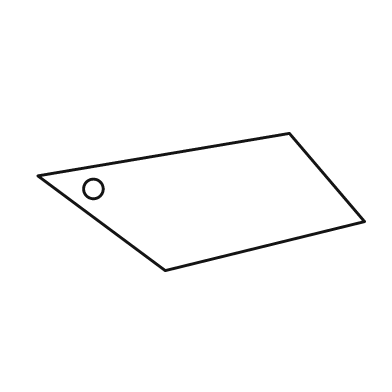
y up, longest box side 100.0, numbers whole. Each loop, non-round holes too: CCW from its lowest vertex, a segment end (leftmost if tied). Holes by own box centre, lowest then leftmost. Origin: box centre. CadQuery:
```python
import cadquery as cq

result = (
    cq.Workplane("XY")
    .moveTo(-11.0, -21.0)
    .lineTo(50.0, -6.0)
    .lineTo(27.0, 21.0)
    .lineTo(-50.0, 8.0)
    .close()
    .moveTo(-33.0, 4.0)
    .circle(3.0)
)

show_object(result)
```